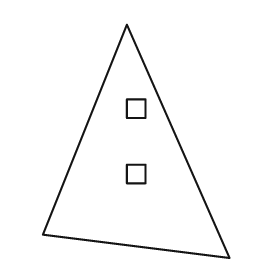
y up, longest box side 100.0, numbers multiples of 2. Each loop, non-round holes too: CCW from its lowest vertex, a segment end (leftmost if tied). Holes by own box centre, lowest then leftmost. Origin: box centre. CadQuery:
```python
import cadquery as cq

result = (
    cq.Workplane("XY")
    .moveTo(40.0, -50.0)
    .lineTo(-4.0, 50.0)
    .lineTo(-40.0, -40.0)
    .close()
    .moveTo(-4.0, -18.0)
    .lineTo(4.0, -18.0)
    .lineTo(4.0, -10.0)
    .lineTo(-4.0, -10.0)
    .close()
    .moveTo(-4.0, 10.0)
    .lineTo(4.0, 10.0)
    .lineTo(4.0, 18.0)
    .lineTo(-4.0, 18.0)
    .close()
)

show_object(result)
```